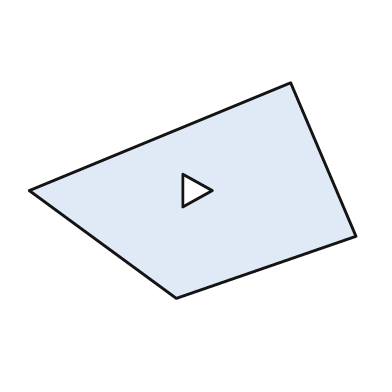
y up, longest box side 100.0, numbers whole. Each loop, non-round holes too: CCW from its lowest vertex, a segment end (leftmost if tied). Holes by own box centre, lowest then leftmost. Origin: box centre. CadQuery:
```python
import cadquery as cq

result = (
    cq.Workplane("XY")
    .moveTo(-5.0, -33.0)
    .lineTo(50.0, -14.0)
    .lineTo(30.0, 33.0)
    .lineTo(-50.0, 0.0)
    .close()
    .moveTo(-3.0, -5.0)
    .lineTo(6.0, 0.0)
    .lineTo(-3.0, 5.0)
    .close()
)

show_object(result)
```